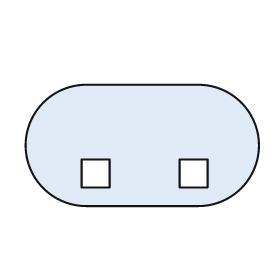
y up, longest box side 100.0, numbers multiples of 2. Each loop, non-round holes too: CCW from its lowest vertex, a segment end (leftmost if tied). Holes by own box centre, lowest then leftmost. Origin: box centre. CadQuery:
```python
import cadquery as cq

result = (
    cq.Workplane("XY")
    .moveTo(-24.0, -26.0)
    .lineTo(24.0, -26.0)
    .threePointArc((50.0, 0.0), (24.0, 26.0))
    .lineTo(-24.0, 26.0)
    .threePointArc((-50.0, 0.0), (-24.0, -26.0))
    .close()
    .moveTo(-26.0, -18.0)
    .lineTo(-14.0, -18.0)
    .lineTo(-14.0, -6.0)
    .lineTo(-26.0, -6.0)
    .close()
    .moveTo(16.0, -18.0)
    .lineTo(28.0, -18.0)
    .lineTo(28.0, -6.0)
    .lineTo(16.0, -6.0)
    .close()
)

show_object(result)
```